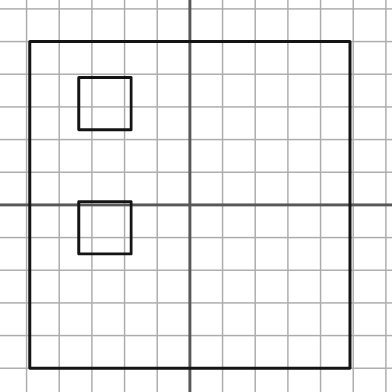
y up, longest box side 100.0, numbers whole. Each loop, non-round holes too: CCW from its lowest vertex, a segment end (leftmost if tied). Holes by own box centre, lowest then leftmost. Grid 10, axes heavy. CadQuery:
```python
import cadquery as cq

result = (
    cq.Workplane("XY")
    .moveTo(-49.0, -50.0)
    .lineTo(49.0, -50.0)
    .lineTo(49.0, 50.0)
    .lineTo(-49.0, 50.0)
    .close()
    .moveTo(-34.0, -15.0)
    .lineTo(-18.0, -15.0)
    .lineTo(-18.0, 1.0)
    .lineTo(-34.0, 1.0)
    .close()
    .moveTo(-34.0, 23.0)
    .lineTo(-18.0, 23.0)
    .lineTo(-18.0, 39.0)
    .lineTo(-34.0, 39.0)
    .close()
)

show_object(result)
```